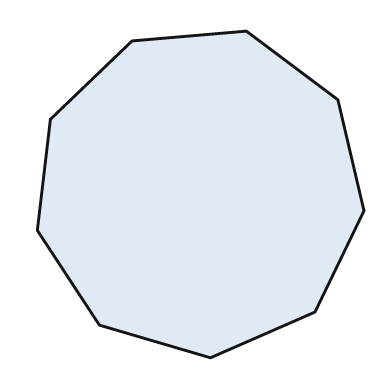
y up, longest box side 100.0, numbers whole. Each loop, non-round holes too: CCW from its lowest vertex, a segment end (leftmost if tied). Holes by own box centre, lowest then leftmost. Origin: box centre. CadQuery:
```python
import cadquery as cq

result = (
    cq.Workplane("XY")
    .moveTo(3.0, -50.0)
    .lineTo(35.0, -36.0)
    .lineTo(50.0, -5.0)
    .lineTo(42.0, 29.0)
    .lineTo(14.0, 50.0)
    .lineTo(-21.0, 47.0)
    .lineTo(-46.0, 23.0)
    .lineTo(-50.0, -11.0)
    .lineTo(-31.0, -40.0)
    .close()
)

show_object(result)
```